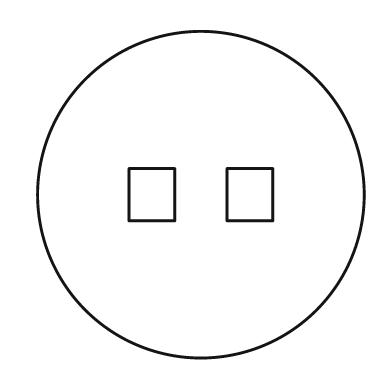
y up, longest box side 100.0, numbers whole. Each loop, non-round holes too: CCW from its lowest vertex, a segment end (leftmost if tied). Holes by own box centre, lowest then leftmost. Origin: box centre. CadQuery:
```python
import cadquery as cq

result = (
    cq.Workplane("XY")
    .moveTo(0.0, 0.0)
    .circle(50.0)
    .moveTo(-22.0, -8.0)
    .lineTo(-8.0, -8.0)
    .lineTo(-8.0, 8.0)
    .lineTo(-22.0, 8.0)
    .close()
    .moveTo(8.0, -8.0)
    .lineTo(22.0, -8.0)
    .lineTo(22.0, 8.0)
    .lineTo(8.0, 8.0)
    .close()
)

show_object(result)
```